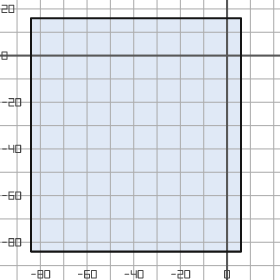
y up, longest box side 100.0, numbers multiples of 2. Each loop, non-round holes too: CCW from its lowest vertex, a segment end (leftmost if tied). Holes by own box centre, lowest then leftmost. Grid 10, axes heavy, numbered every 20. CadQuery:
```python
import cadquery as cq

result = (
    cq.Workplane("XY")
    .moveTo(-84.0, -84.0)
    .lineTo(6.0, -84.0)
    .lineTo(6.0, 16.0)
    .lineTo(-84.0, 16.0)
    .close()
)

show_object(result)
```